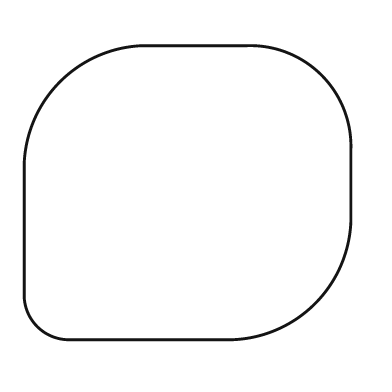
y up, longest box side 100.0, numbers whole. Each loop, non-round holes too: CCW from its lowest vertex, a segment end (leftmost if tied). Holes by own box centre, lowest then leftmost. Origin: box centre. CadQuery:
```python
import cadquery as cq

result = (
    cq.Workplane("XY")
    .moveTo(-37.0, -45.0)
    .lineTo(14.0, -45.0)
    .threePointArc((39.0, -34.0), (50.0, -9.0))
    .lineTo(50.0, 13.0)
    .threePointArc((41.0, 36.0), (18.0, 45.0))
    .lineTo(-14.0, 45.0)
    .threePointArc((-39.0, 34.0), (-50.0, 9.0))
    .lineTo(-50.0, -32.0)
    .threePointArc((-46.0, -41.0), (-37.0, -45.0))
    .close()
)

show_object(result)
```